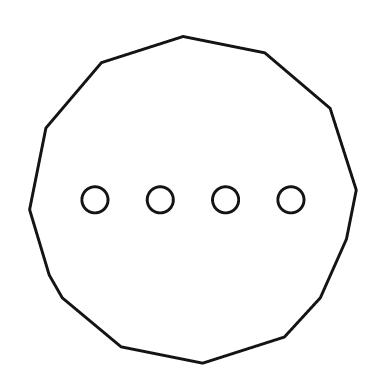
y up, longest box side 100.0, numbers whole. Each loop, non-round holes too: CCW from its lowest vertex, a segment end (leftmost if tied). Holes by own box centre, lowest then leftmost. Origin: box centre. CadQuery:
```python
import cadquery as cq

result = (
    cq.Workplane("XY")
    .moveTo(3.0, -50.0)
    .lineTo(28.0, -42.0)
    .lineTo(39.0, -30.0)
    .lineTo(47.0, -12.0)
    .lineTo(50.0, 3.0)
    .lineTo(42.0, 28.0)
    .lineTo(22.0, 45.0)
    .lineTo(-3.0, 50.0)
    .lineTo(-28.0, 42.0)
    .lineTo(-45.0, 22.0)
    .lineTo(-50.0, -3.0)
    .lineTo(-44.0, -23.0)
    .lineTo(-40.0, -30.0)
    .lineTo(-22.0, -45.0)
    .close()
    .moveTo(-30.0, 0.0)
    .circle(4.0)
    .moveTo(-10.0, 0.0)
    .circle(4.0)
    .moveTo(10.0, 0.0)
    .circle(4.0)
    .moveTo(30.0, 0.0)
    .circle(4.0)
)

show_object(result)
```